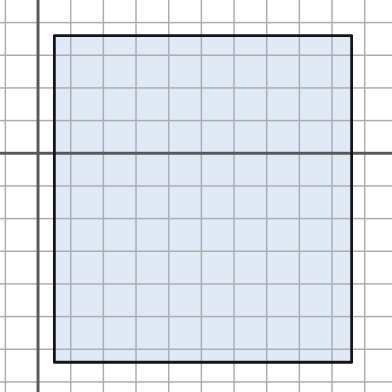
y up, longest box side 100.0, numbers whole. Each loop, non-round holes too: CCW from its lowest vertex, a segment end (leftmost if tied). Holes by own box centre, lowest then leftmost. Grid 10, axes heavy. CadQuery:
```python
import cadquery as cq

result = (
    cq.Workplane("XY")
    .moveTo(5.0, -64.0)
    .lineTo(96.0, -64.0)
    .lineTo(96.0, 36.0)
    .lineTo(5.0, 36.0)
    .close()
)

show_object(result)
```